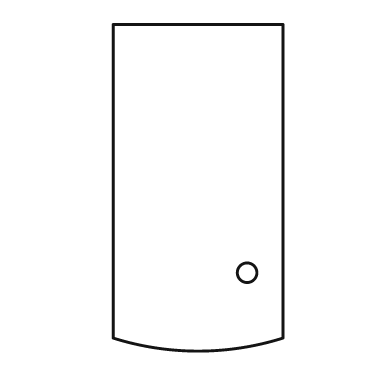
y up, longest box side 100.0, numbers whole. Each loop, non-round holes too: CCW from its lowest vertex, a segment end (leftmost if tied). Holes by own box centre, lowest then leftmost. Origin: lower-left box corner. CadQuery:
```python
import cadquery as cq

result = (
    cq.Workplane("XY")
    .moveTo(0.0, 4.0)
    .threePointArc((26.0, 0.0), (52.0, 4.0))
    .lineTo(52.0, 100.0)
    .lineTo(0.0, 100.0)
    .close()
    .moveTo(41.0, 24.0)
    .circle(3.0)
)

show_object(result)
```